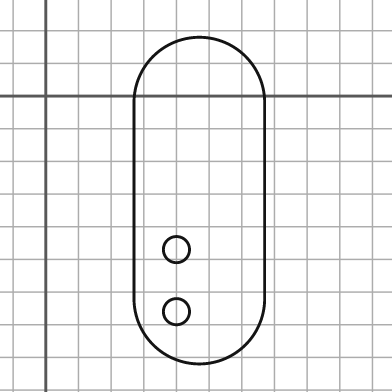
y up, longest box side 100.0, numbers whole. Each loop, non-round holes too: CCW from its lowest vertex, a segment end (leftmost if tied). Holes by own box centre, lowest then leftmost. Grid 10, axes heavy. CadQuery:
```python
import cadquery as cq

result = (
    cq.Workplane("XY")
    .moveTo(27.0, -62.0)
    .threePointArc((47.0, -82.0), (67.0, -62.0))
    .lineTo(67.0, -2.0)
    .threePointArc((47.0, 18.0), (27.0, -2.0))
    .close()
    .moveTo(40.0, -66.0)
    .circle(4.0)
    .moveTo(40.0, -47.0)
    .circle(4.0)
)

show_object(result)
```